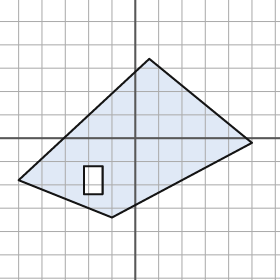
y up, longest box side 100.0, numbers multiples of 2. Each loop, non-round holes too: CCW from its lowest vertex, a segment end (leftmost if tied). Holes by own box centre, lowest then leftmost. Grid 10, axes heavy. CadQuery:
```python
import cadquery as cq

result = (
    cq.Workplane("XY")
    .moveTo(-10.0, -34.0)
    .lineTo(50.0, -2.0)
    .lineTo(6.0, 34.0)
    .lineTo(-50.0, -18.0)
    .close()
    .moveTo(-22.0, -24.0)
    .lineTo(-14.0, -24.0)
    .lineTo(-14.0, -12.0)
    .lineTo(-22.0, -12.0)
    .close()
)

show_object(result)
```